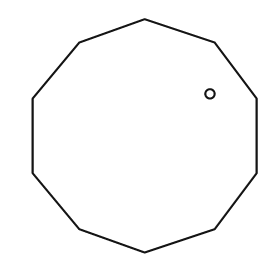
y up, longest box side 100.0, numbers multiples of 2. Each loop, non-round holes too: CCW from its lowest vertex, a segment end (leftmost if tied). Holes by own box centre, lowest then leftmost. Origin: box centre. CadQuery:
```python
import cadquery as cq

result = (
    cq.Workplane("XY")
    .moveTo(0.0, -50.0)
    .lineTo(30.0, -40.0)
    .lineTo(48.0, -16.0)
    .lineTo(48.0, 16.0)
    .lineTo(30.0, 40.0)
    .lineTo(0.0, 50.0)
    .lineTo(-28.0, 40.0)
    .lineTo(-48.0, 16.0)
    .lineTo(-48.0, -16.0)
    .lineTo(-28.0, -40.0)
    .close()
    .moveTo(28.0, 18.0)
    .circle(2.0)
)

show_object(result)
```